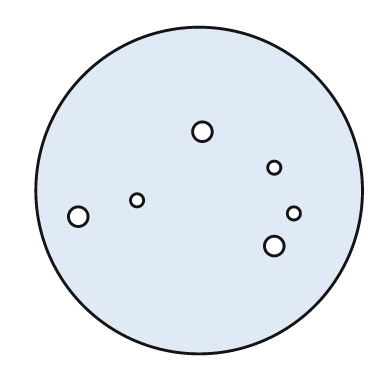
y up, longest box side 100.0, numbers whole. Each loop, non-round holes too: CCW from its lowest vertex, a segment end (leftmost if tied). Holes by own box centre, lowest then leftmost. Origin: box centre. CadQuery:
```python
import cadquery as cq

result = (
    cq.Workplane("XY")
    .moveTo(0.0, 0.0)
    .circle(50.0)
    .moveTo(23.0, -17.0)
    .circle(3.0)
    .moveTo(-37.0, -8.0)
    .circle(3.0)
    .moveTo(29.0, -7.0)
    .circle(2.0)
    .moveTo(-19.0, -3.0)
    .circle(2.0)
    .moveTo(23.0, 7.0)
    .circle(2.0)
    .moveTo(1.0, 18.0)
    .circle(3.0)
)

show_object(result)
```